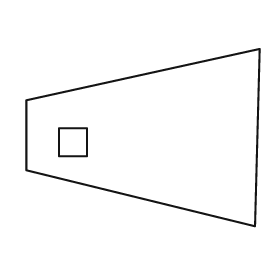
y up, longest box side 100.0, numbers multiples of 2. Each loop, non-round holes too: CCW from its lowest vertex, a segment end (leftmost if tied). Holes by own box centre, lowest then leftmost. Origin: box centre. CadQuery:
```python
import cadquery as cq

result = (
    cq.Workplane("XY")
    .moveTo(48.0, -38.0)
    .lineTo(50.0, 38.0)
    .lineTo(-50.0, 16.0)
    .lineTo(-50.0, -14.0)
    .close()
    .moveTo(-36.0, -8.0)
    .lineTo(-24.0, -8.0)
    .lineTo(-24.0, 4.0)
    .lineTo(-36.0, 4.0)
    .close()
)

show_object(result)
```